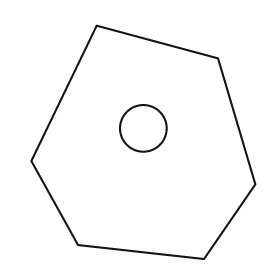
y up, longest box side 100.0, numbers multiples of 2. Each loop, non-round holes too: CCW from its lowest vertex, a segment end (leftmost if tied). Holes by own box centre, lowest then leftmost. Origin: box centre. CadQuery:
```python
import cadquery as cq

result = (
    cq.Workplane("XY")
    .moveTo(26.0, -50.0)
    .lineTo(48.0, -18.0)
    .lineTo(32.0, 36.0)
    .lineTo(-20.0, 50.0)
    .lineTo(-48.0, -8.0)
    .lineTo(-28.0, -44.0)
    .close()
    .moveTo(0.0, 6.0)
    .circle(10.0)
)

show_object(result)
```